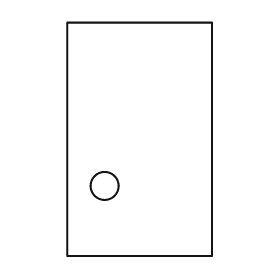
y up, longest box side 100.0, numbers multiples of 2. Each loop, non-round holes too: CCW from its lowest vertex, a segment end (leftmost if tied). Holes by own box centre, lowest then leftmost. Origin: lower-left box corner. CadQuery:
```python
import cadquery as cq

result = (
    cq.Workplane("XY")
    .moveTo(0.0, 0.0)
    .lineTo(62.0, 0.0)
    .lineTo(62.0, 100.0)
    .lineTo(0.0, 100.0)
    .close()
    .moveTo(16.0, 30.0)
    .circle(6.0)
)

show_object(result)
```